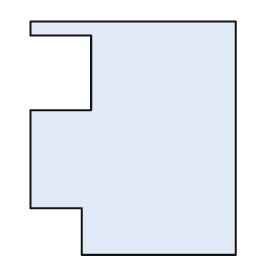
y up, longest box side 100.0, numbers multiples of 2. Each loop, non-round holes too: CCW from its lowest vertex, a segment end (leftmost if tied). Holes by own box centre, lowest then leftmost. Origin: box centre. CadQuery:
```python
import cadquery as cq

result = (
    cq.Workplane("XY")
    .moveTo(-22.0, -50.0)
    .lineTo(44.0, -50.0)
    .lineTo(44.0, 50.0)
    .lineTo(-44.0, 50.0)
    .lineTo(-44.0, 44.0)
    .lineTo(-18.0, 44.0)
    .lineTo(-18.0, 12.0)
    .lineTo(-44.0, 12.0)
    .lineTo(-44.0, -30.0)
    .lineTo(-22.0, -30.0)
    .close()
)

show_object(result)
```